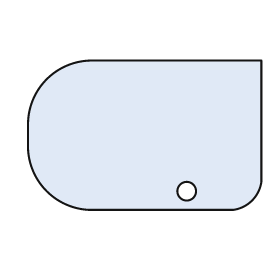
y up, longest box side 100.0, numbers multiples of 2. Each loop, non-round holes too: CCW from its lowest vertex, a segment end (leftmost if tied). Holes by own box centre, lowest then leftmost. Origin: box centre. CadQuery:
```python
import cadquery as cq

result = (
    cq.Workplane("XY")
    .moveTo(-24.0, -32.0)
    .lineTo(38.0, -32.0)
    .threePointArc((46.0, -28.0), (50.0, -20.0))
    .lineTo(50.0, 32.0)
    .lineTo(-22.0, 32.0)
    .threePointArc((-42.0, 24.0), (-50.0, 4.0))
    .lineTo(-50.0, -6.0)
    .threePointArc((-42.0, -24.0), (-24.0, -32.0))
    .close()
    .moveTo(18.0, -24.0)
    .circle(4.0)
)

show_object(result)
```